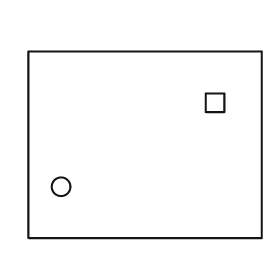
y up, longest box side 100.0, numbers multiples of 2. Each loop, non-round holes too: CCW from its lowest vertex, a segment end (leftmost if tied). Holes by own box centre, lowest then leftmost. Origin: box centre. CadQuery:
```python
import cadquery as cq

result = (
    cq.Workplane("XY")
    .moveTo(-50.0, -40.0)
    .lineTo(50.0, -40.0)
    .lineTo(50.0, 40.0)
    .lineTo(-50.0, 40.0)
    .close()
    .moveTo(-36.0, -18.0)
    .circle(4.0)
    .moveTo(26.0, 14.0)
    .lineTo(34.0, 14.0)
    .lineTo(34.0, 22.0)
    .lineTo(26.0, 22.0)
    .close()
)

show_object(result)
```